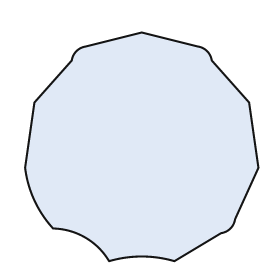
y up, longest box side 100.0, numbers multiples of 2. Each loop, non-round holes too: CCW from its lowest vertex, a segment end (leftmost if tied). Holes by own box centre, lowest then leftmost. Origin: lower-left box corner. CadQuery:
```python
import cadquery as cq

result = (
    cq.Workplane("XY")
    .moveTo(36.0, 0.0)
    .threePointArc((50.0, 2.0), (64.0, 0.0))
    .lineTo(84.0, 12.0)
    .threePointArc((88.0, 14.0), (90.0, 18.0))
    .lineTo(100.0, 40.0)
    .lineTo(96.0, 68.0)
    .lineTo(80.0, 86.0)
    .threePointArc((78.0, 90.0), (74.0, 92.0))
    .lineTo(50.0, 98.0)
    .lineTo(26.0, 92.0)
    .threePointArc((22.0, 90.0), (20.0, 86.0))
    .lineTo(4.0, 68.0)
    .lineTo(0.0, 40.0)
    .threePointArc((4.0, 26.0), (12.0, 14.0))
    .threePointArc((26.0, 10.0), (36.0, 0.0))
    .close()
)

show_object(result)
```